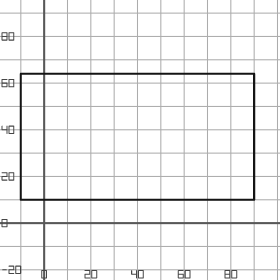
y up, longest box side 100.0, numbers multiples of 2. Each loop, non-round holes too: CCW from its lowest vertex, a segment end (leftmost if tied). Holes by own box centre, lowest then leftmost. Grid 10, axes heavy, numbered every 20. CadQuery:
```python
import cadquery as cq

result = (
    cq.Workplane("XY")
    .moveTo(-10.0, 10.0)
    .lineTo(90.0, 10.0)
    .lineTo(90.0, 64.0)
    .lineTo(-10.0, 64.0)
    .close()
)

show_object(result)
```